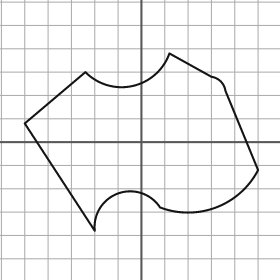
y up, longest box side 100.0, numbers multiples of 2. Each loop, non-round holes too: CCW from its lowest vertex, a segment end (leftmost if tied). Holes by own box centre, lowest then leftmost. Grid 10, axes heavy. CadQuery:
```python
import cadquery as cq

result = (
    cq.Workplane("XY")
    .moveTo(-20.0, -38.0)
    .threePointArc((-10.0, -22.0), (8.0, -28.0))
    .threePointArc((32.0, -28.0), (50.0, -12.0))
    .lineTo(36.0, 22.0)
    .threePointArc((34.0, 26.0), (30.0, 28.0))
    .lineTo(12.0, 38.0)
    .threePointArc((-4.0, 24.0), (-24.0, 30.0))
    .lineTo(-50.0, 8.0)
    .close()
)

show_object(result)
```